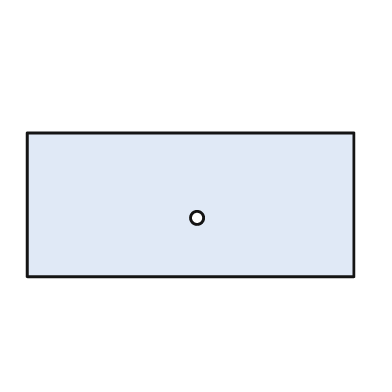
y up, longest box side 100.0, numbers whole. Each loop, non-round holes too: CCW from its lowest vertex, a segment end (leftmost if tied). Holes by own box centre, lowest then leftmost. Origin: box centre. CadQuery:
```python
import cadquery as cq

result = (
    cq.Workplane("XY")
    .moveTo(-50.0, -22.0)
    .lineTo(50.0, -22.0)
    .lineTo(50.0, 22.0)
    .lineTo(-50.0, 22.0)
    .close()
    .moveTo(2.0, -4.0)
    .circle(2.0)
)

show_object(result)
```